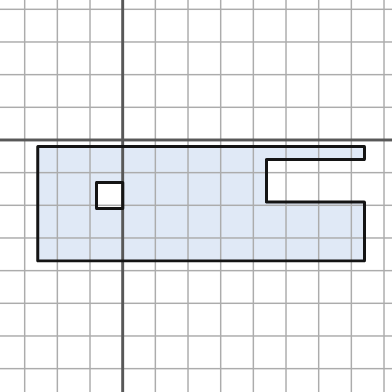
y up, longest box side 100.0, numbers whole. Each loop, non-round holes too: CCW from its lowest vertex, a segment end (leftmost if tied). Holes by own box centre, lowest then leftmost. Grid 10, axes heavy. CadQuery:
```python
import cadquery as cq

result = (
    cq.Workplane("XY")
    .moveTo(-26.0, -37.0)
    .lineTo(74.0, -37.0)
    .lineTo(74.0, -19.0)
    .lineTo(44.0, -19.0)
    .lineTo(44.0, -6.0)
    .lineTo(74.0, -6.0)
    .lineTo(74.0, -2.0)
    .lineTo(-26.0, -2.0)
    .close()
    .moveTo(-8.0, -21.0)
    .lineTo(0.0, -21.0)
    .lineTo(0.0, -13.0)
    .lineTo(-8.0, -13.0)
    .close()
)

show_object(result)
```